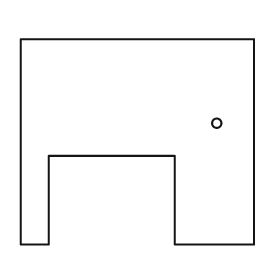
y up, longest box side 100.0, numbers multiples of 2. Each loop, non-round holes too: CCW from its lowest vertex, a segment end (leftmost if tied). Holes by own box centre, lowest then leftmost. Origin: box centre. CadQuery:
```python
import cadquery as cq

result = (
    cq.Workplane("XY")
    .moveTo(-50.0, -44.0)
    .lineTo(-38.0, -44.0)
    .lineTo(-38.0, -6.0)
    .lineTo(16.0, -6.0)
    .lineTo(16.0, -44.0)
    .lineTo(50.0, -44.0)
    .lineTo(50.0, 44.0)
    .lineTo(-50.0, 44.0)
    .close()
    .moveTo(34.0, 8.0)
    .circle(2.0)
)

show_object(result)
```